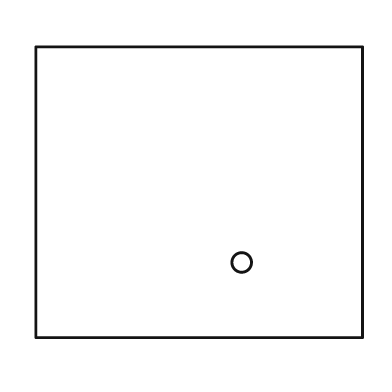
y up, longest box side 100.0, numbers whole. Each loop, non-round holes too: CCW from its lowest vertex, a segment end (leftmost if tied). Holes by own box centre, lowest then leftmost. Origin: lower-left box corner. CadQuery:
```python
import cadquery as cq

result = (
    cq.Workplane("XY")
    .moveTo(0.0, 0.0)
    .lineTo(100.0, 0.0)
    .lineTo(100.0, 89.0)
    .lineTo(0.0, 89.0)
    .close()
    .moveTo(63.0, 23.0)
    .circle(3.0)
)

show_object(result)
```